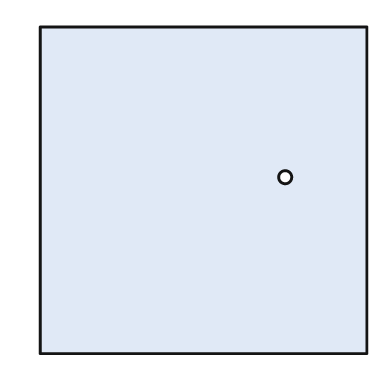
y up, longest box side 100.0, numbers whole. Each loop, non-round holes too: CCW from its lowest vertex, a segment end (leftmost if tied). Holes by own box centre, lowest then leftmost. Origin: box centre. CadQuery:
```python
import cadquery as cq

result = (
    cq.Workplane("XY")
    .moveTo(-50.0, -50.0)
    .lineTo(50.0, -50.0)
    .lineTo(50.0, 50.0)
    .lineTo(-50.0, 50.0)
    .close()
    .moveTo(25.0, 4.0)
    .circle(2.0)
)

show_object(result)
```